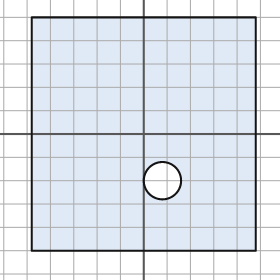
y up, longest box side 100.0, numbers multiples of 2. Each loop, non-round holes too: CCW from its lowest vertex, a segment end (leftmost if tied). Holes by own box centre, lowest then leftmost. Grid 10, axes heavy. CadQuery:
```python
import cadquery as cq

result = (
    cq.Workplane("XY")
    .moveTo(-48.0, -50.0)
    .lineTo(48.0, -50.0)
    .lineTo(48.0, 50.0)
    .lineTo(-48.0, 50.0)
    .close()
    .moveTo(8.0, -20.0)
    .circle(8.0)
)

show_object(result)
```